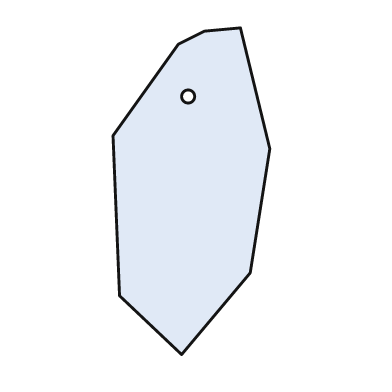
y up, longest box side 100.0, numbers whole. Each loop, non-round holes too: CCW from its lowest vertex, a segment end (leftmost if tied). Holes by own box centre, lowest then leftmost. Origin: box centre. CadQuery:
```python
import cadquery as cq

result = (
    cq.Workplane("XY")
    .moveTo(-3.0, -50.0)
    .lineTo(18.0, -25.0)
    .lineTo(24.0, 13.0)
    .lineTo(15.0, 50.0)
    .lineTo(4.0, 49.0)
    .lineTo(-4.0, 45.0)
    .lineTo(-24.0, 17.0)
    .lineTo(-22.0, -32.0)
    .close()
    .moveTo(-1.0, 29.0)
    .circle(2.0)
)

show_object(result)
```